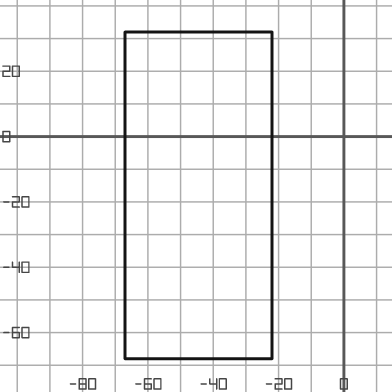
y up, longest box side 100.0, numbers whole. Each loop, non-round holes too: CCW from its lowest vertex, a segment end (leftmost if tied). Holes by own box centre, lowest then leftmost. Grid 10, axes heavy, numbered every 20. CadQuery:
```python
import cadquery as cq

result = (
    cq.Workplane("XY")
    .moveTo(-67.0, -68.0)
    .lineTo(-22.0, -68.0)
    .lineTo(-22.0, 32.0)
    .lineTo(-67.0, 32.0)
    .close()
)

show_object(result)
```